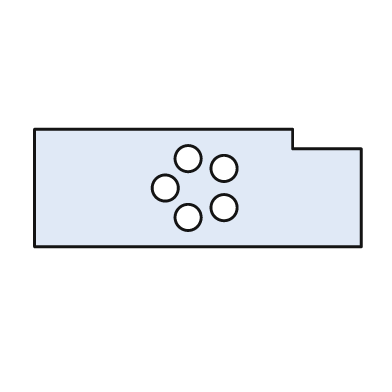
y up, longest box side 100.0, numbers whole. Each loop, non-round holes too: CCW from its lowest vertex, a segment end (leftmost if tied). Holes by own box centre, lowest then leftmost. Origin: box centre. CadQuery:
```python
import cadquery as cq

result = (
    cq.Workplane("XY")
    .moveTo(-50.0, -18.0)
    .lineTo(50.0, -18.0)
    .lineTo(50.0, 12.0)
    .lineTo(29.0, 12.0)
    .lineTo(29.0, 18.0)
    .lineTo(-50.0, 18.0)
    .close()
    .moveTo(-3.0, -9.0)
    .circle(4.0)
    .moveTo(8.0, -6.0)
    .circle(4.0)
    .moveTo(-10.0, 0.0)
    .circle(4.0)
    .moveTo(8.0, 6.0)
    .circle(4.0)
    .moveTo(-3.0, 9.0)
    .circle(4.0)
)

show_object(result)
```